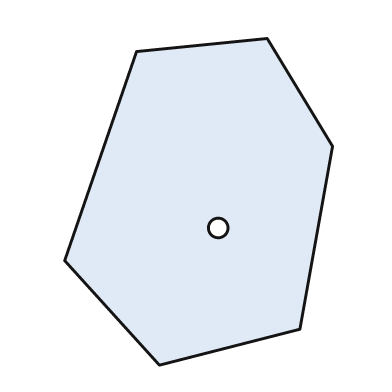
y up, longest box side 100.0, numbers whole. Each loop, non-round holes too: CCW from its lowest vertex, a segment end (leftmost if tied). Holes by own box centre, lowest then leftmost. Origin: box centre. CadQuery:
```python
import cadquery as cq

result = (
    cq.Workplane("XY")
    .moveTo(-12.0, -50.0)
    .lineTo(31.0, -39.0)
    .lineTo(41.0, 17.0)
    .lineTo(21.0, 50.0)
    .lineTo(-19.0, 46.0)
    .lineTo(-41.0, -18.0)
    .close()
    .moveTo(6.0, -8.0)
    .circle(3.0)
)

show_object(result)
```